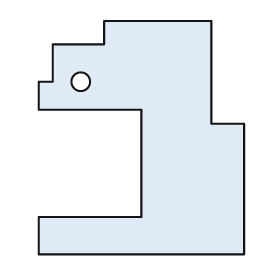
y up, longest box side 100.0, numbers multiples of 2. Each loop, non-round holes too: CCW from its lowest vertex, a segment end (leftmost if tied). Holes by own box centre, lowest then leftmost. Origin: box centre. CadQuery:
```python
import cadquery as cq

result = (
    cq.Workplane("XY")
    .moveTo(-44.0, -50.0)
    .lineTo(44.0, -50.0)
    .lineTo(44.0, 6.0)
    .lineTo(30.0, 6.0)
    .lineTo(30.0, 50.0)
    .lineTo(-16.0, 50.0)
    .lineTo(-16.0, 40.0)
    .lineTo(-38.0, 40.0)
    .lineTo(-38.0, 24.0)
    .lineTo(-44.0, 24.0)
    .lineTo(-44.0, 12.0)
    .lineTo(0.0, 12.0)
    .lineTo(0.0, -34.0)
    .lineTo(-44.0, -34.0)
    .close()
    .moveTo(-26.0, 24.0)
    .circle(4.0)
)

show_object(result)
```